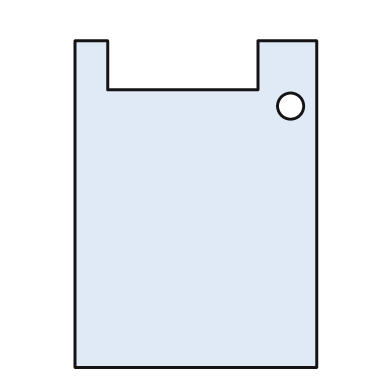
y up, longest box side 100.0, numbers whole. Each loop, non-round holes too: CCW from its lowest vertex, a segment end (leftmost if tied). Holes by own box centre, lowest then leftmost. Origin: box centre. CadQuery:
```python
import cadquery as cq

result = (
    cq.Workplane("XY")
    .moveTo(-37.0, -50.0)
    .lineTo(37.0, -50.0)
    .lineTo(37.0, 50.0)
    .lineTo(19.0, 50.0)
    .lineTo(19.0, 35.0)
    .lineTo(-27.0, 35.0)
    .lineTo(-27.0, 50.0)
    .lineTo(-37.0, 50.0)
    .close()
    .moveTo(29.0, 30.0)
    .circle(4.0)
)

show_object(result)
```